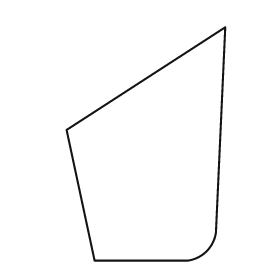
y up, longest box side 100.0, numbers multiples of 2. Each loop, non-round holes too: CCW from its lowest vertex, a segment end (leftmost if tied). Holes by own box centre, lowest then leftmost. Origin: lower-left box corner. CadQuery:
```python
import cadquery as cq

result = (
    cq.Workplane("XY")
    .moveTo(12.0, 0.0)
    .lineTo(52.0, 0.0)
    .threePointArc((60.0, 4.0), (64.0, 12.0))
    .lineTo(68.0, 100.0)
    .lineTo(0.0, 56.0)
    .close()
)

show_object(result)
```